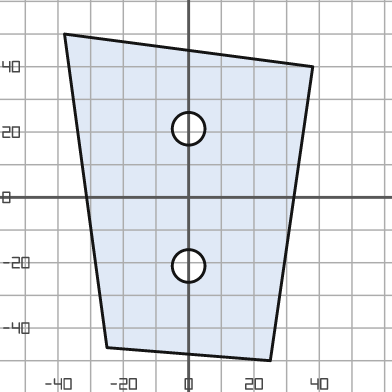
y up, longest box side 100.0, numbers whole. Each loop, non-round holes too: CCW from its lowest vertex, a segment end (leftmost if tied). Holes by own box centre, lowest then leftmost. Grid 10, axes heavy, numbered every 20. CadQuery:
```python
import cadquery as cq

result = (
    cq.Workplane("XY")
    .moveTo(25.0, -50.0)
    .lineTo(38.0, 40.0)
    .lineTo(-38.0, 50.0)
    .lineTo(-25.0, -46.0)
    .close()
    .moveTo(0.0, -21.0)
    .circle(5.0)
    .moveTo(0.0, 21.0)
    .circle(5.0)
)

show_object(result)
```